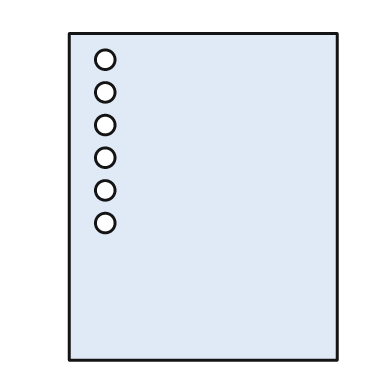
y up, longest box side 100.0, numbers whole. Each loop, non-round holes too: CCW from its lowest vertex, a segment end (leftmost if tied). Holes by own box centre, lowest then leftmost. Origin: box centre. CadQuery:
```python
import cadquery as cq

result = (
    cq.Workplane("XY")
    .moveTo(-41.0, -50.0)
    .lineTo(41.0, -50.0)
    .lineTo(41.0, 50.0)
    .lineTo(-41.0, 50.0)
    .close()
    .moveTo(-30.0, -8.0)
    .circle(3.0)
    .moveTo(-30.0, 2.0)
    .circle(3.0)
    .moveTo(-30.0, 12.0)
    .circle(3.0)
    .moveTo(-30.0, 22.0)
    .circle(3.0)
    .moveTo(-30.0, 32.0)
    .circle(3.0)
    .moveTo(-30.0, 42.0)
    .circle(3.0)
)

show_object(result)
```